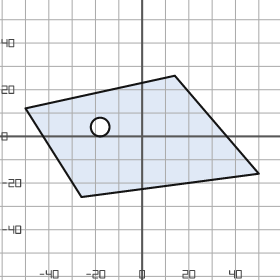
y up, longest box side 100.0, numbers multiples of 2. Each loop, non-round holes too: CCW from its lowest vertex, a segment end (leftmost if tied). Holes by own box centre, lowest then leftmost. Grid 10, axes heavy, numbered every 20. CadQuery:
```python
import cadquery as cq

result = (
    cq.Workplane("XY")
    .moveTo(-26.0, -26.0)
    .lineTo(50.0, -16.0)
    .lineTo(14.0, 26.0)
    .lineTo(-50.0, 12.0)
    .close()
    .moveTo(-18.0, 4.0)
    .circle(4.0)
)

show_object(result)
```